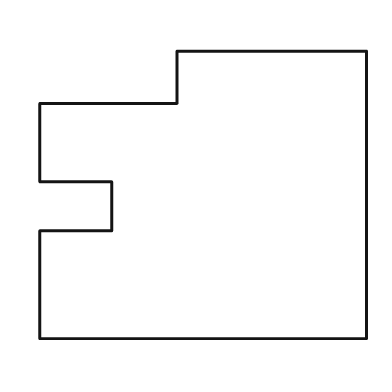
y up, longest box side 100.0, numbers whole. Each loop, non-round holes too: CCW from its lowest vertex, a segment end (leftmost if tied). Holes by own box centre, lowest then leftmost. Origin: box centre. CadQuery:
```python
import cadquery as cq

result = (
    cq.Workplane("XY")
    .moveTo(-50.0, -44.0)
    .lineTo(50.0, -44.0)
    .lineTo(50.0, 44.0)
    .lineTo(-8.0, 44.0)
    .lineTo(-8.0, 28.0)
    .lineTo(-50.0, 28.0)
    .lineTo(-50.0, 4.0)
    .lineTo(-28.0, 4.0)
    .lineTo(-28.0, -11.0)
    .lineTo(-50.0, -11.0)
    .close()
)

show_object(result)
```